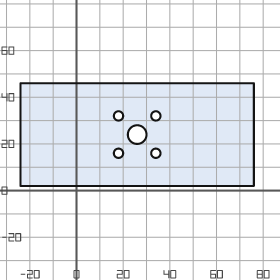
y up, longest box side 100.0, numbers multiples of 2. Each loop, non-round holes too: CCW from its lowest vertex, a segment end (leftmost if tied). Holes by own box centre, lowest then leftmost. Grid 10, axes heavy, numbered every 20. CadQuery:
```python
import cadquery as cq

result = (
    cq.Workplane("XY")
    .moveTo(-24.0, 2.0)
    .lineTo(76.0, 2.0)
    .lineTo(76.0, 46.0)
    .lineTo(-24.0, 46.0)
    .close()
    .moveTo(18.0, 16.0)
    .circle(2.0)
    .moveTo(34.0, 16.0)
    .circle(2.0)
    .moveTo(26.0, 24.0)
    .circle(4.0)
    .moveTo(18.0, 32.0)
    .circle(2.0)
    .moveTo(34.0, 32.0)
    .circle(2.0)
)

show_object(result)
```